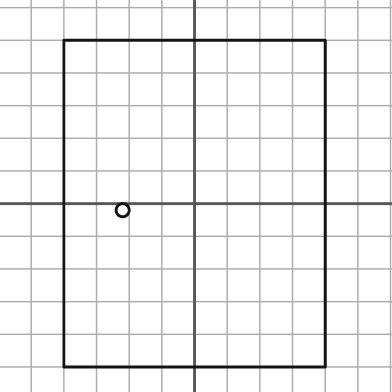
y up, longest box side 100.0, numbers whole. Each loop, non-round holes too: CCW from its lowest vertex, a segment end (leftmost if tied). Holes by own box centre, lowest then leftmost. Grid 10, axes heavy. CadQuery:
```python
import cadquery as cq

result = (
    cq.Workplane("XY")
    .moveTo(-40.0, -50.0)
    .lineTo(40.0, -50.0)
    .lineTo(40.0, 50.0)
    .lineTo(-40.0, 50.0)
    .close()
    .moveTo(-22.0, -2.0)
    .circle(2.0)
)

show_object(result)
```